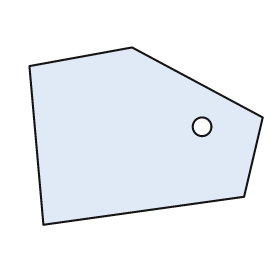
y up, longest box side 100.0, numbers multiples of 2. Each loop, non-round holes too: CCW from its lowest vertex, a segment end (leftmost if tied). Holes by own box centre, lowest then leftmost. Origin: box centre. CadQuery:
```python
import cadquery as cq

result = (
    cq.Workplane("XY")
    .moveTo(-44.0, -38.0)
    .lineTo(42.0, -26.0)
    .lineTo(50.0, 8.0)
    .lineTo(-6.0, 38.0)
    .lineTo(-50.0, 30.0)
    .close()
    .moveTo(24.0, 4.0)
    .circle(4.0)
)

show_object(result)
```